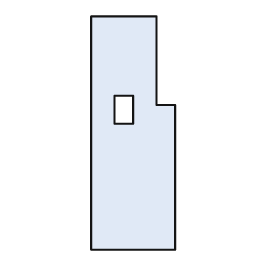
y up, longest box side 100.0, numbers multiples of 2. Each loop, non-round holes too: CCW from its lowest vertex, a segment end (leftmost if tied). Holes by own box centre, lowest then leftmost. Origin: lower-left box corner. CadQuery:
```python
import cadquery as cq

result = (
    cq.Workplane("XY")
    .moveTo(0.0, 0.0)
    .lineTo(36.0, 0.0)
    .lineTo(36.0, 62.0)
    .lineTo(28.0, 62.0)
    .lineTo(28.0, 100.0)
    .lineTo(0.0, 100.0)
    .close()
    .moveTo(10.0, 54.0)
    .lineTo(18.0, 54.0)
    .lineTo(18.0, 66.0)
    .lineTo(10.0, 66.0)
    .close()
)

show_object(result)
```